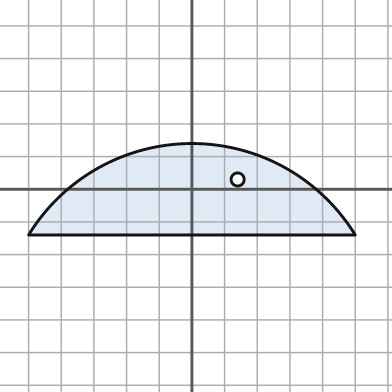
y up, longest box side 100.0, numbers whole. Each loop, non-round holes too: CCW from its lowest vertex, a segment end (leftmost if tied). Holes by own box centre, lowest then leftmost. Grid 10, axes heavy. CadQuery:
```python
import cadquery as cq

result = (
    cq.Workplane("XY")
    .moveTo(-50.0, -14.0)
    .lineTo(50.0, -14.0)
    .threePointArc((0.0, 14.0), (-50.0, -14.0))
    .close()
    .moveTo(14.0, 3.0)
    .circle(2.0)
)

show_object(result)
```